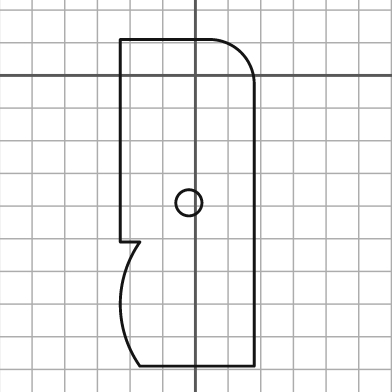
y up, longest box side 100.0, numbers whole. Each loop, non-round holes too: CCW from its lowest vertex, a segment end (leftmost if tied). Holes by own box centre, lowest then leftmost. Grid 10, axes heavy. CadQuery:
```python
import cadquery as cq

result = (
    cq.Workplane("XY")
    .moveTo(-17.0, -89.0)
    .lineTo(18.0, -89.0)
    .lineTo(18.0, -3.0)
    .threePointArc((14.0, 7.0), (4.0, 11.0))
    .lineTo(-23.0, 11.0)
    .lineTo(-23.0, -51.0)
    .lineTo(-17.0, -51.0)
    .threePointArc((-23.0, -70.0), (-17.0, -89.0))
    .close()
    .moveTo(-2.0, -39.0)
    .circle(4.0)
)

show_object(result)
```